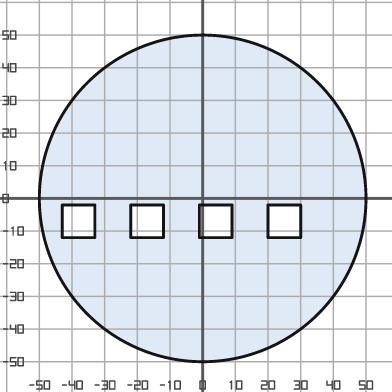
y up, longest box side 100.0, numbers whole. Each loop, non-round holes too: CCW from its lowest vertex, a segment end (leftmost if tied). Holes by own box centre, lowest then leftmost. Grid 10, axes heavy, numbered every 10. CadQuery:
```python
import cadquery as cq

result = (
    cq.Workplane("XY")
    .moveTo(0.0, 0.0)
    .circle(50.0)
    .moveTo(-43.0, -12.0)
    .lineTo(-33.0, -12.0)
    .lineTo(-33.0, -2.0)
    .lineTo(-43.0, -2.0)
    .close()
    .moveTo(-22.0, -12.0)
    .lineTo(-12.0, -12.0)
    .lineTo(-12.0, -2.0)
    .lineTo(-22.0, -2.0)
    .close()
    .moveTo(-1.0, -12.0)
    .lineTo(9.0, -12.0)
    .lineTo(9.0, -2.0)
    .lineTo(-1.0, -2.0)
    .close()
    .moveTo(20.0, -12.0)
    .lineTo(30.0, -12.0)
    .lineTo(30.0, -2.0)
    .lineTo(20.0, -2.0)
    .close()
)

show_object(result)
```